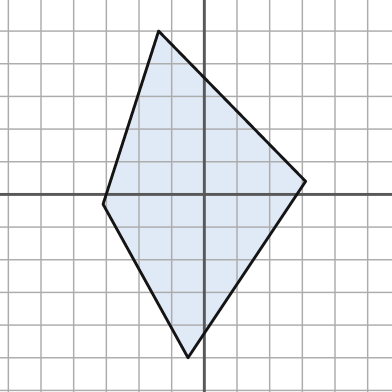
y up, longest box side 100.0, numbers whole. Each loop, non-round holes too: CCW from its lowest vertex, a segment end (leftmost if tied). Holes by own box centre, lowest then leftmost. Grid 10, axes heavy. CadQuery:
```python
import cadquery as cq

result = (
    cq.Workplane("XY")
    .moveTo(-5.0, -50.0)
    .lineTo(31.0, 4.0)
    .lineTo(-14.0, 50.0)
    .lineTo(-31.0, -3.0)
    .close()
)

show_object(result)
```